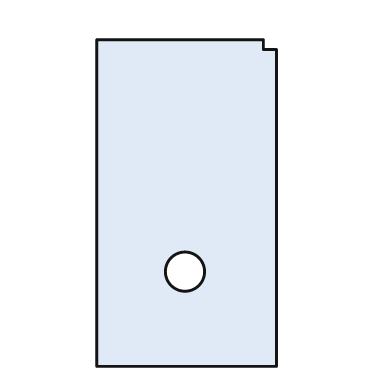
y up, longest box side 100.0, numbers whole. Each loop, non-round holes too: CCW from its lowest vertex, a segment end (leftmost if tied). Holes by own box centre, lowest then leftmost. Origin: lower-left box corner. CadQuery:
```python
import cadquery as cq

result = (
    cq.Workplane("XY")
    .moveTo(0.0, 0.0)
    .lineTo(55.0, 0.0)
    .lineTo(55.0, 97.0)
    .lineTo(51.0, 97.0)
    .lineTo(51.0, 100.0)
    .lineTo(0.0, 100.0)
    .close()
    .moveTo(27.0, 29.0)
    .circle(6.0)
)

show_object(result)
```